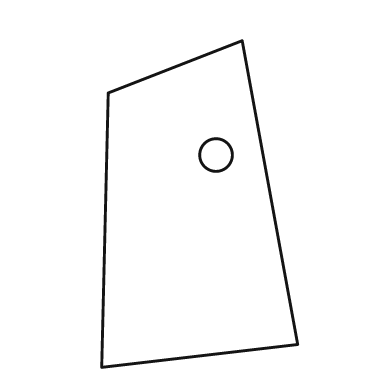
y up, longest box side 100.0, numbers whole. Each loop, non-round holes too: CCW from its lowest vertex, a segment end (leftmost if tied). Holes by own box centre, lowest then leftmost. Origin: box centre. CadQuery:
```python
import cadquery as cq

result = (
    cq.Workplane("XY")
    .moveTo(-30.0, -50.0)
    .lineTo(30.0, -43.0)
    .lineTo(13.0, 50.0)
    .lineTo(-28.0, 34.0)
    .close()
    .moveTo(5.0, 15.0)
    .circle(5.0)
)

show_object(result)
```